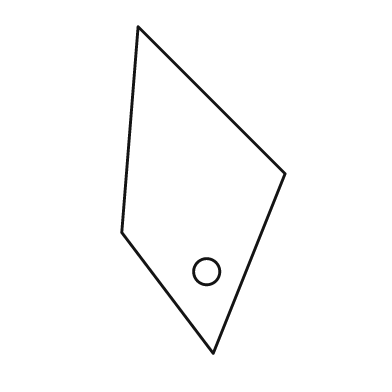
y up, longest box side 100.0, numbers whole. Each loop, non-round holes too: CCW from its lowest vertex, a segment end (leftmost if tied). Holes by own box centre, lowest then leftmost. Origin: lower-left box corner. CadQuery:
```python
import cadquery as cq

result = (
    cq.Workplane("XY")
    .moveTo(28.0, 0.0)
    .lineTo(50.0, 55.0)
    .lineTo(5.0, 100.0)
    .lineTo(0.0, 37.0)
    .close()
    .moveTo(26.0, 25.0)
    .circle(4.0)
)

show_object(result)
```